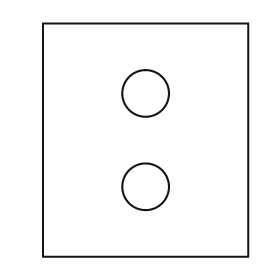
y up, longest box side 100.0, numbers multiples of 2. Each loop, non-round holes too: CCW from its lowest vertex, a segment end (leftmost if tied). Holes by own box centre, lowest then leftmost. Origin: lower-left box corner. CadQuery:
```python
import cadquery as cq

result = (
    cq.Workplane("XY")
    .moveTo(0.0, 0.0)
    .lineTo(88.0, 0.0)
    .lineTo(88.0, 100.0)
    .lineTo(0.0, 100.0)
    .close()
    .moveTo(44.0, 30.0)
    .circle(10.0)
    .moveTo(44.0, 70.0)
    .circle(10.0)
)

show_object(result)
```